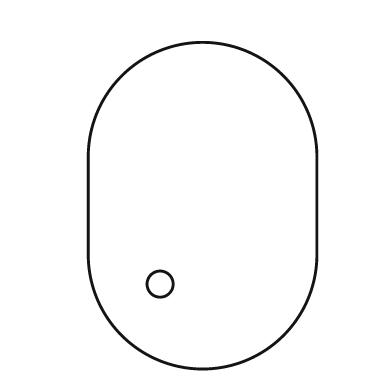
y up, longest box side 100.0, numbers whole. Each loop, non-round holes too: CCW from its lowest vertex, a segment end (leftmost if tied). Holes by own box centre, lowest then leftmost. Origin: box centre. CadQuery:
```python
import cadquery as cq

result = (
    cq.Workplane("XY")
    .moveTo(-35.0, -15.0)
    .threePointArc((0.0, -50.0), (35.0, -15.0))
    .lineTo(35.0, 15.0)
    .threePointArc((0.0, 50.0), (-35.0, 15.0))
    .close()
    .moveTo(-13.0, -24.0)
    .circle(4.0)
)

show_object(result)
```